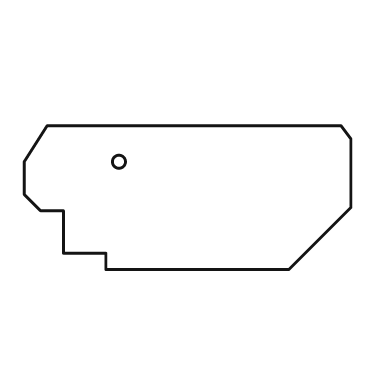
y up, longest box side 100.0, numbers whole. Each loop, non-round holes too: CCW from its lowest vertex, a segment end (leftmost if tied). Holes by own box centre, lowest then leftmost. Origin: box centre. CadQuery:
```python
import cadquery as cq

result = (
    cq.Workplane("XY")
    .moveTo(-25.0, -22.0)
    .lineTo(31.0, -22.0)
    .lineTo(50.0, -3.0)
    .lineTo(50.0, 18.0)
    .lineTo(47.0, 22.0)
    .lineTo(-43.0, 22.0)
    .lineTo(-50.0, 11.0)
    .lineTo(-50.0, 1.0)
    .lineTo(-45.0, -4.0)
    .lineTo(-38.0, -4.0)
    .lineTo(-38.0, -17.0)
    .lineTo(-25.0, -17.0)
    .close()
    .moveTo(-21.0, 11.0)
    .circle(2.0)
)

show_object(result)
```